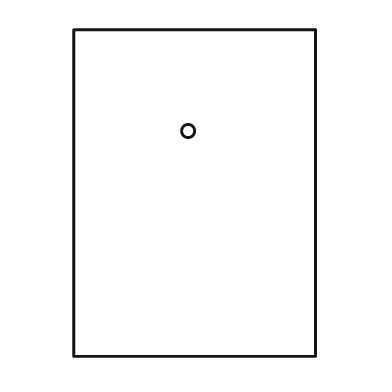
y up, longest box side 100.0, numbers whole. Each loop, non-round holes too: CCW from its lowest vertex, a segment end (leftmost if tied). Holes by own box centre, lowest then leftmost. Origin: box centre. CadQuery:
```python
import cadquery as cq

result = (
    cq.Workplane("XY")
    .moveTo(-37.0, -50.0)
    .lineTo(37.0, -50.0)
    .lineTo(37.0, 50.0)
    .lineTo(-37.0, 50.0)
    .close()
    .moveTo(-2.0, 19.0)
    .circle(2.0)
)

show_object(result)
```